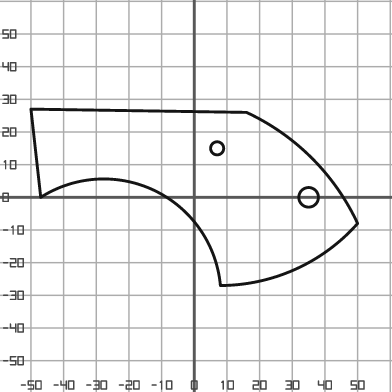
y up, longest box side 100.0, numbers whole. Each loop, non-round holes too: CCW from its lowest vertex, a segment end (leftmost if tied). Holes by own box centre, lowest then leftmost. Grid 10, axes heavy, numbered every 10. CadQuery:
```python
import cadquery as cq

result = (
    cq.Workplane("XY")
    .moveTo(8.0, -27.0)
    .threePointArc((31.0, -22.0), (50.0, -8.0))
    .threePointArc((36.0, 12.0), (16.0, 26.0))
    .lineTo(-50.0, 27.0)
    .lineTo(-47.0, 0.0)
    .threePointArc((-12.0, 2.0), (8.0, -27.0))
    .close()
    .moveTo(35.0, 0.0)
    .circle(3.0)
    .moveTo(7.0, 15.0)
    .circle(2.0)
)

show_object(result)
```